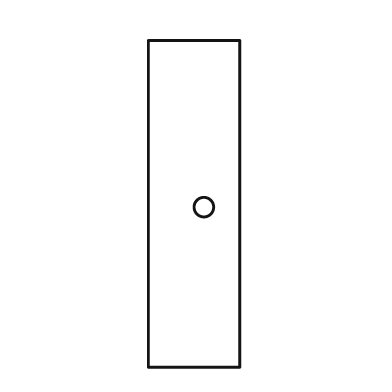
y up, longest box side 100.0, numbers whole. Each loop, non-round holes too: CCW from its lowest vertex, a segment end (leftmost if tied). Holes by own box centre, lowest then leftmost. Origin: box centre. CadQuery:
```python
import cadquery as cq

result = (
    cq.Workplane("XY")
    .moveTo(-14.0, -50.0)
    .lineTo(14.0, -50.0)
    .lineTo(14.0, 50.0)
    .lineTo(-14.0, 50.0)
    .close()
    .moveTo(3.0, -1.0)
    .circle(3.0)
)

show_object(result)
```